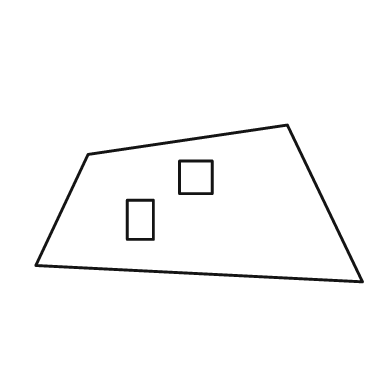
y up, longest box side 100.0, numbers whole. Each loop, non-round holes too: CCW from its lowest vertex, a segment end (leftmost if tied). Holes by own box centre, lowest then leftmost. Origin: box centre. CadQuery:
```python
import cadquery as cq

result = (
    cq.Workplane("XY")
    .moveTo(50.0, -24.0)
    .lineTo(27.0, 24.0)
    .lineTo(-34.0, 15.0)
    .lineTo(-50.0, -19.0)
    .close()
    .moveTo(-22.0, -11.0)
    .lineTo(-14.0, -11.0)
    .lineTo(-14.0, 1.0)
    .lineTo(-22.0, 1.0)
    .close()
    .moveTo(-6.0, 3.0)
    .lineTo(4.0, 3.0)
    .lineTo(4.0, 13.0)
    .lineTo(-6.0, 13.0)
    .close()
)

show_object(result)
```